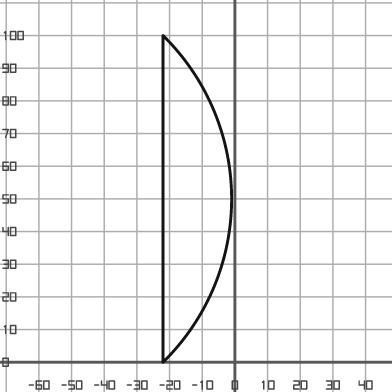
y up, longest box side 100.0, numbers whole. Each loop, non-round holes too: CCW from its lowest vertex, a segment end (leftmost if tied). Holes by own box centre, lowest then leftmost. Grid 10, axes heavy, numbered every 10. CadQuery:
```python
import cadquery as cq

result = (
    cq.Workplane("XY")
    .moveTo(-22.0, 0.0)
    .threePointArc((-1.0, 50.0), (-22.0, 100.0))
    .close()
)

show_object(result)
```